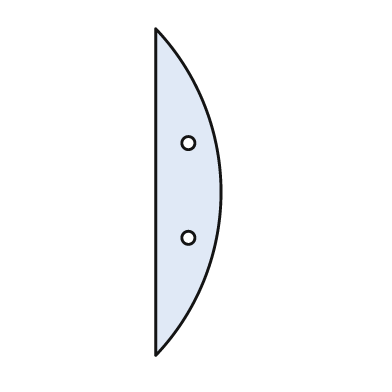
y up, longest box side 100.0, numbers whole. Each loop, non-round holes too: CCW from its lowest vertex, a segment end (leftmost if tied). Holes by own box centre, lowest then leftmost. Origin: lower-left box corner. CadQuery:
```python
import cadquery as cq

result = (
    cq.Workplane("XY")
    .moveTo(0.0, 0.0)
    .threePointArc((20.0, 50.0), (0.0, 100.0))
    .close()
    .moveTo(10.0, 36.0)
    .circle(2.0)
    .moveTo(10.0, 65.0)
    .circle(2.0)
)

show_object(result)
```